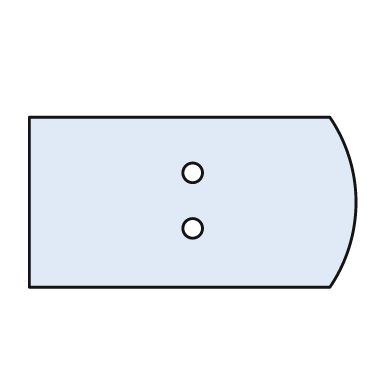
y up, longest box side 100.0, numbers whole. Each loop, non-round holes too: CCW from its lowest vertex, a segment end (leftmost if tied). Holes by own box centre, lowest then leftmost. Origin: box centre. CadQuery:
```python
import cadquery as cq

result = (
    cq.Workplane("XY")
    .moveTo(-50.0, -26.0)
    .lineTo(42.0, -26.0)
    .threePointArc((50.0, 0.0), (42.0, 26.0))
    .lineTo(-50.0, 26.0)
    .close()
    .moveTo(0.0, -8.0)
    .circle(3.0)
    .moveTo(0.0, 9.0)
    .circle(3.0)
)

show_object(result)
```